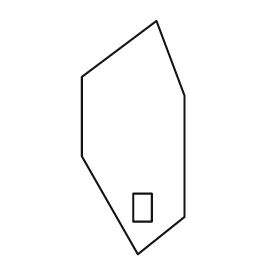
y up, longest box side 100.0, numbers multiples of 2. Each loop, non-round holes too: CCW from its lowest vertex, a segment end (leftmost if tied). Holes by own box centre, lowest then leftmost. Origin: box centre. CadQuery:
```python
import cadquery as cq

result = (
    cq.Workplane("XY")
    .moveTo(2.0, -50.0)
    .lineTo(22.0, -34.0)
    .lineTo(22.0, 18.0)
    .lineTo(10.0, 50.0)
    .lineTo(-22.0, 26.0)
    .lineTo(-22.0, -8.0)
    .close()
    .moveTo(0.0, -36.0)
    .lineTo(8.0, -36.0)
    .lineTo(8.0, -24.0)
    .lineTo(0.0, -24.0)
    .close()
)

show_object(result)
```